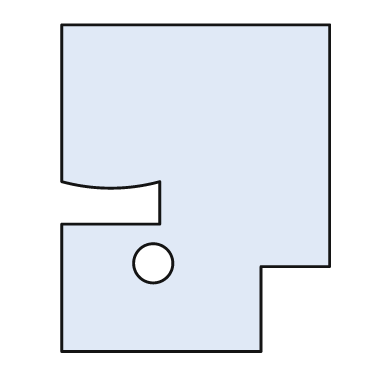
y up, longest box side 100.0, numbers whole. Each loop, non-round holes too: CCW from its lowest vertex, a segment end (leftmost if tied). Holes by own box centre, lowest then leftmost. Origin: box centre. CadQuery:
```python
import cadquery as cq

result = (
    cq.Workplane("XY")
    .moveTo(-41.0, -50.0)
    .lineTo(20.0, -50.0)
    .lineTo(20.0, -24.0)
    .lineTo(41.0, -24.0)
    .lineTo(41.0, 50.0)
    .lineTo(-41.0, 50.0)
    .lineTo(-41.0, 2.0)
    .threePointArc((-26.0, 0.0), (-11.0, 2.0))
    .lineTo(-11.0, -11.0)
    .lineTo(-41.0, -11.0)
    .close()
    .moveTo(-13.0, -23.0)
    .circle(6.0)
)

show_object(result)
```